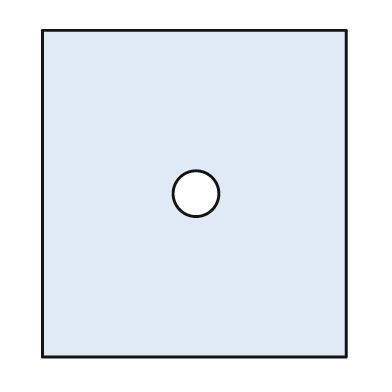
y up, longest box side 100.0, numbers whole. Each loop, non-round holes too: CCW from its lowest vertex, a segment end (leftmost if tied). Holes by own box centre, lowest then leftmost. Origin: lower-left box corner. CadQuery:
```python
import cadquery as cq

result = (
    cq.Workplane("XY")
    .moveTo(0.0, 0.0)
    .lineTo(93.0, 0.0)
    .lineTo(93.0, 100.0)
    .lineTo(0.0, 100.0)
    .close()
    .moveTo(47.0, 50.0)
    .circle(7.0)
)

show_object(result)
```